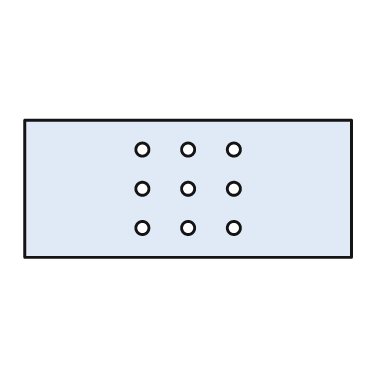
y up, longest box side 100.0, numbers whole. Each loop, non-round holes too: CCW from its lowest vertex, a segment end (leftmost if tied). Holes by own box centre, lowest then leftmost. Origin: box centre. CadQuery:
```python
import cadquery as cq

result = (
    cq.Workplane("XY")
    .moveTo(-50.0, -21.0)
    .lineTo(50.0, -21.0)
    .lineTo(50.0, 21.0)
    .lineTo(-50.0, 21.0)
    .close()
    .moveTo(-14.0, -12.0)
    .circle(2.0)
    .moveTo(0.0, -12.0)
    .circle(2.0)
    .moveTo(14.0, -12.0)
    .circle(2.0)
    .moveTo(-14.0, 0.0)
    .circle(2.0)
    .moveTo(0.0, 0.0)
    .circle(2.0)
    .moveTo(14.0, 0.0)
    .circle(2.0)
    .moveTo(-14.0, 12.0)
    .circle(2.0)
    .moveTo(0.0, 12.0)
    .circle(2.0)
    .moveTo(14.0, 12.0)
    .circle(2.0)
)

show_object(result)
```